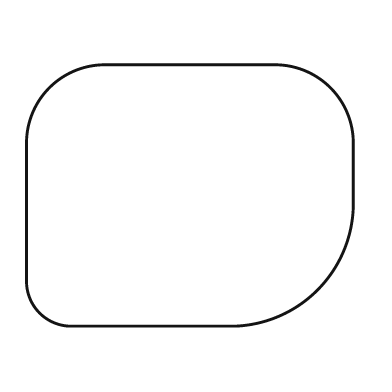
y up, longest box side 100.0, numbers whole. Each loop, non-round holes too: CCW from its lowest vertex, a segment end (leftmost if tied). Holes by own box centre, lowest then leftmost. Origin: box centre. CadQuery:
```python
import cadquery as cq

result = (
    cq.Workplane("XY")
    .moveTo(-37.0, -40.0)
    .lineTo(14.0, -40.0)
    .threePointArc((39.0, -29.0), (50.0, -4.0))
    .lineTo(50.0, 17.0)
    .threePointArc((43.0, 33.0), (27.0, 40.0))
    .lineTo(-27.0, 40.0)
    .threePointArc((-43.0, 33.0), (-50.0, 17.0))
    .lineTo(-50.0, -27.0)
    .threePointArc((-46.0, -36.0), (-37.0, -40.0))
    .close()
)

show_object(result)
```